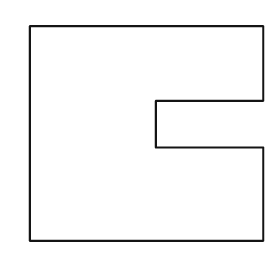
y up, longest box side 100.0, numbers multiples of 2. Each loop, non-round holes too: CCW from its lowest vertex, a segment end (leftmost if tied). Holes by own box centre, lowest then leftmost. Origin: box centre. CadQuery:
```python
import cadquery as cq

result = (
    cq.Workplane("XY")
    .moveTo(-50.0, -46.0)
    .lineTo(50.0, -46.0)
    .lineTo(50.0, -6.0)
    .lineTo(4.0, -6.0)
    .lineTo(4.0, 14.0)
    .lineTo(50.0, 14.0)
    .lineTo(50.0, 46.0)
    .lineTo(-50.0, 46.0)
    .close()
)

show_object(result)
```